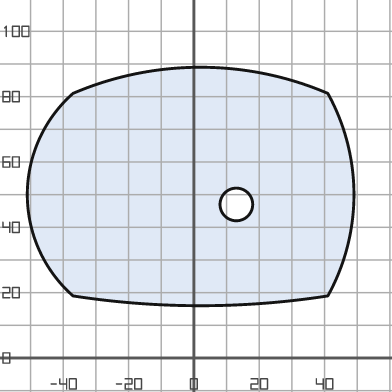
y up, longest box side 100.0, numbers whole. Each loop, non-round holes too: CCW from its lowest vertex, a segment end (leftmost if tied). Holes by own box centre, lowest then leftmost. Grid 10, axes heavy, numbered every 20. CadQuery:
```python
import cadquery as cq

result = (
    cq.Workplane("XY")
    .moveTo(-37.0, 19.0)
    .threePointArc((2.0, 16.0), (41.0, 19.0))
    .threePointArc((49.0, 50.0), (41.0, 81.0))
    .threePointArc((2.0, 89.0), (-37.0, 81.0))
    .threePointArc((-51.0, 50.0), (-37.0, 19.0))
    .close()
    .moveTo(13.0, 47.0)
    .circle(5.0)
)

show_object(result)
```